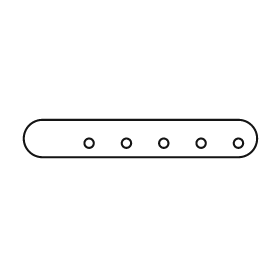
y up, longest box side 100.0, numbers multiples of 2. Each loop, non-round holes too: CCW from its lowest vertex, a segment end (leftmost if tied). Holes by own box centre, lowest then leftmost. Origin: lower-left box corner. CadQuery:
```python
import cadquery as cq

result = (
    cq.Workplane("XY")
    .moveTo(8.0, 0.0)
    .lineTo(92.0, 0.0)
    .threePointArc((100.0, 8.0), (92.0, 16.0))
    .lineTo(8.0, 16.0)
    .threePointArc((0.0, 8.0), (8.0, 0.0))
    .close()
    .moveTo(28.0, 6.0)
    .circle(2.0)
    .moveTo(44.0, 6.0)
    .circle(2.0)
    .moveTo(60.0, 6.0)
    .circle(2.0)
    .moveTo(76.0, 6.0)
    .circle(2.0)
    .moveTo(92.0, 6.0)
    .circle(2.0)
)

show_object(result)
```